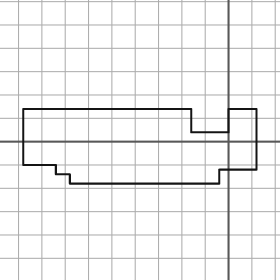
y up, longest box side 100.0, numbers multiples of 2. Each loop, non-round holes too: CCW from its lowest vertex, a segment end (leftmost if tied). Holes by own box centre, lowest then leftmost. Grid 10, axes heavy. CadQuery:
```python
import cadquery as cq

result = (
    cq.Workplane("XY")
    .moveTo(-68.0, -18.0)
    .lineTo(-4.0, -18.0)
    .lineTo(-4.0, -12.0)
    .lineTo(12.0, -12.0)
    .lineTo(12.0, 14.0)
    .lineTo(0.0, 14.0)
    .lineTo(0.0, 4.0)
    .lineTo(-16.0, 4.0)
    .lineTo(-16.0, 14.0)
    .lineTo(-88.0, 14.0)
    .lineTo(-88.0, -10.0)
    .lineTo(-74.0, -10.0)
    .lineTo(-74.0, -14.0)
    .lineTo(-68.0, -14.0)
    .close()
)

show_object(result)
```